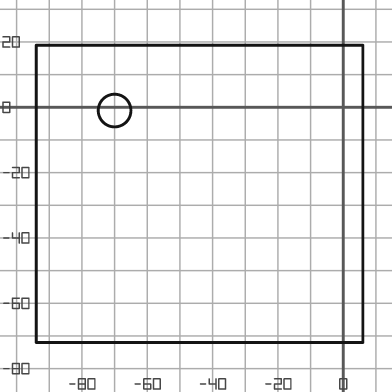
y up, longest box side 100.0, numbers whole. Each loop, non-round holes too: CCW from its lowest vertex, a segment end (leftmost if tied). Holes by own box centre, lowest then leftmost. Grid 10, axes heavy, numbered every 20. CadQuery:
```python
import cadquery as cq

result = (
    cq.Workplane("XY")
    .moveTo(-94.0, -72.0)
    .lineTo(6.0, -72.0)
    .lineTo(6.0, 19.0)
    .lineTo(-94.0, 19.0)
    .close()
    .moveTo(-70.0, -1.0)
    .circle(5.0)
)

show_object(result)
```